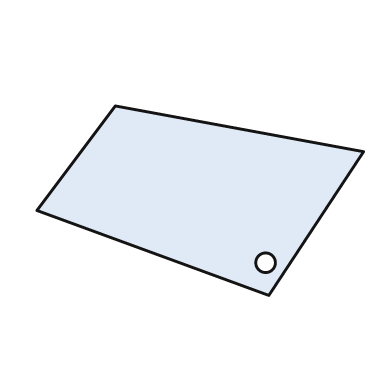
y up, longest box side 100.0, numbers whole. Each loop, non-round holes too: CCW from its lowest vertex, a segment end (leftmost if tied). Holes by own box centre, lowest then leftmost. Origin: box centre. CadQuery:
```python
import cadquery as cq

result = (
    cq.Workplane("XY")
    .moveTo(21.0, -29.0)
    .lineTo(50.0, 15.0)
    .lineTo(-26.0, 29.0)
    .lineTo(-50.0, -3.0)
    .close()
    .moveTo(20.0, -19.0)
    .circle(3.0)
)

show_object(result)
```